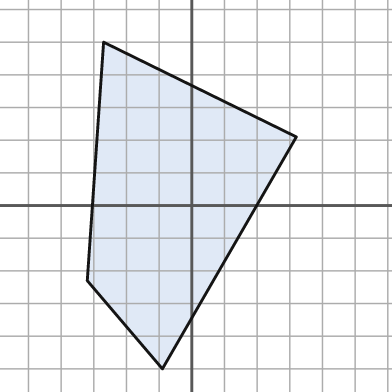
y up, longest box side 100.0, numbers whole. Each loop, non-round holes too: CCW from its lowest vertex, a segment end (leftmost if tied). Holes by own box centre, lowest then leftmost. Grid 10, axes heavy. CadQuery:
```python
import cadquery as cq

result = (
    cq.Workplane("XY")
    .moveTo(-9.0, -50.0)
    .lineTo(32.0, 21.0)
    .lineTo(-27.0, 50.0)
    .lineTo(-32.0, -23.0)
    .close()
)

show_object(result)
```